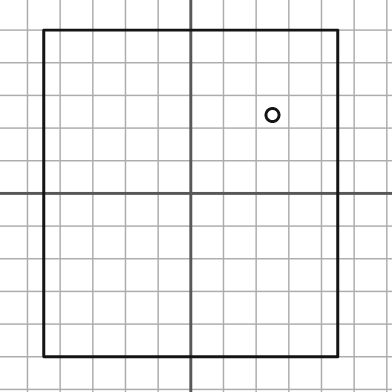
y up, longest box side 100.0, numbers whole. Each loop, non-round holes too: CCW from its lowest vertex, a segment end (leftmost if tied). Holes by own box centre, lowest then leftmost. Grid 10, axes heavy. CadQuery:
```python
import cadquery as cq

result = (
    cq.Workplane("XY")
    .moveTo(-45.0, -50.0)
    .lineTo(45.0, -50.0)
    .lineTo(45.0, 50.0)
    .lineTo(-45.0, 50.0)
    .close()
    .moveTo(25.0, 24.0)
    .circle(2.0)
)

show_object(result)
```